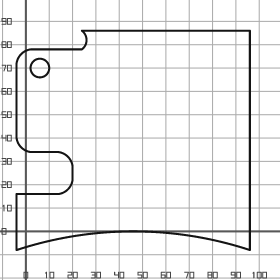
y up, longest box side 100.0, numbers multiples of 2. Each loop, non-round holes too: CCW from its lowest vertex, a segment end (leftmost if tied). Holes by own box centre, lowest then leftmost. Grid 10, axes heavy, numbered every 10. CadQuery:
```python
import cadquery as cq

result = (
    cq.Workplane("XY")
    .moveTo(-4.0, -8.0)
    .threePointArc((46.0, 0.0), (96.0, -8.0))
    .lineTo(96.0, 86.0)
    .lineTo(24.0, 86.0)
    .threePointArc((26.0, 82.0), (24.0, 78.0))
    .lineTo(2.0, 78.0)
    .threePointArc((-2.0, 76.0), (-4.0, 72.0))
    .lineTo(-4.0, 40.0)
    .threePointArc((-2.0, 36.0), (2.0, 34.0))
    .lineTo(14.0, 34.0)
    .threePointArc((18.0, 32.0), (20.0, 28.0))
    .lineTo(20.0, 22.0)
    .threePointArc((18.0, 18.0), (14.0, 16.0))
    .lineTo(-4.0, 16.0)
    .close()
    .moveTo(6.0, 70.0)
    .circle(4.0)
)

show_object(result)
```